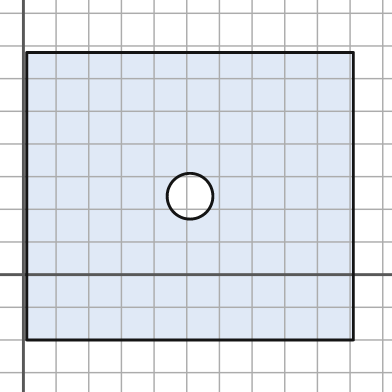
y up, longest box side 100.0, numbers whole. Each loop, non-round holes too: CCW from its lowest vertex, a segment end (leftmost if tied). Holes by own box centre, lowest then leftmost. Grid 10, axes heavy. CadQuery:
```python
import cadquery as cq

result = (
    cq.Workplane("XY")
    .moveTo(1.0, -20.0)
    .lineTo(101.0, -20.0)
    .lineTo(101.0, 68.0)
    .lineTo(1.0, 68.0)
    .close()
    .moveTo(51.0, 24.0)
    .circle(7.0)
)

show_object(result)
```